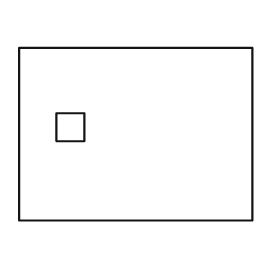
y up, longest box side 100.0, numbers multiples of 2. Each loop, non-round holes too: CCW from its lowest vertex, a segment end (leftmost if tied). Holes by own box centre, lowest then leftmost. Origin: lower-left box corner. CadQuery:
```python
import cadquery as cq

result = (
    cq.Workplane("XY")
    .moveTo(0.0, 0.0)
    .lineTo(100.0, 0.0)
    .lineTo(100.0, 74.0)
    .lineTo(0.0, 74.0)
    .close()
    .moveTo(16.0, 34.0)
    .lineTo(28.0, 34.0)
    .lineTo(28.0, 46.0)
    .lineTo(16.0, 46.0)
    .close()
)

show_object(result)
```